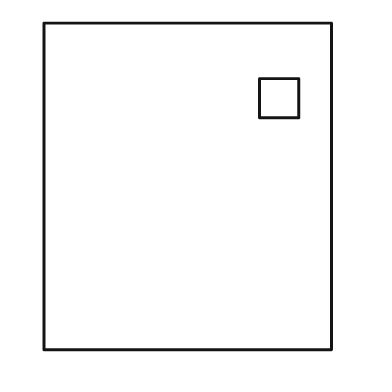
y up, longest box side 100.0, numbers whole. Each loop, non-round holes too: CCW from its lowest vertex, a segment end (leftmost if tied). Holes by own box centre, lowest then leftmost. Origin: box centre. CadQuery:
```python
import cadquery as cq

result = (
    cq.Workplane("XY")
    .moveTo(-44.0, -50.0)
    .lineTo(44.0, -50.0)
    .lineTo(44.0, 50.0)
    .lineTo(-44.0, 50.0)
    .close()
    .moveTo(22.0, 21.0)
    .lineTo(34.0, 21.0)
    .lineTo(34.0, 33.0)
    .lineTo(22.0, 33.0)
    .close()
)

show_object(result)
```